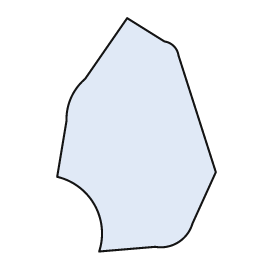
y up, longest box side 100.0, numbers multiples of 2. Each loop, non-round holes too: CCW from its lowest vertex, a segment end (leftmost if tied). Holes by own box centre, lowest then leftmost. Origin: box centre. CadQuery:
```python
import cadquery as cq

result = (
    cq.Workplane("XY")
    .moveTo(-16.0, -50.0)
    .lineTo(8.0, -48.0)
    .threePointArc((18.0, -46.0), (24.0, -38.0))
    .lineTo(34.0, -16.0)
    .lineTo(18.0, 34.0)
    .threePointArc((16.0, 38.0), (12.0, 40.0))
    .lineTo(-4.0, 50.0)
    .lineTo(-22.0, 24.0)
    .threePointArc((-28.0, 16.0), (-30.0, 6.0))
    .lineTo(-34.0, -18.0)
    .threePointArc((-18.0, -30.0), (-16.0, -50.0))
    .close()
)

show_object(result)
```